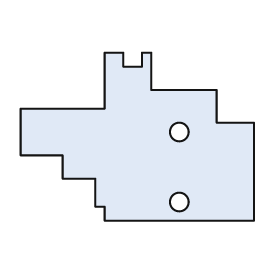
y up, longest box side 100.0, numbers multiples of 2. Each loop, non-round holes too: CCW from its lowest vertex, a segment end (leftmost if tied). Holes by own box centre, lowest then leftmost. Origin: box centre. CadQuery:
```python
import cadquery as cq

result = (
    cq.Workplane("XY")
    .moveTo(-14.0, -36.0)
    .lineTo(50.0, -36.0)
    .lineTo(50.0, 6.0)
    .lineTo(34.0, 6.0)
    .lineTo(34.0, 20.0)
    .lineTo(6.0, 20.0)
    .lineTo(6.0, 36.0)
    .lineTo(2.0, 36.0)
    .lineTo(2.0, 30.0)
    .lineTo(-6.0, 30.0)
    .lineTo(-6.0, 36.0)
    .lineTo(-14.0, 36.0)
    .lineTo(-14.0, 12.0)
    .lineTo(-50.0, 12.0)
    .lineTo(-50.0, -8.0)
    .lineTo(-32.0, -8.0)
    .lineTo(-32.0, -18.0)
    .lineTo(-18.0, -18.0)
    .lineTo(-18.0, -30.0)
    .lineTo(-14.0, -30.0)
    .close()
    .moveTo(18.0, -28.0)
    .circle(4.0)
    .moveTo(18.0, 2.0)
    .circle(4.0)
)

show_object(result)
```